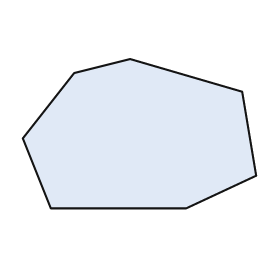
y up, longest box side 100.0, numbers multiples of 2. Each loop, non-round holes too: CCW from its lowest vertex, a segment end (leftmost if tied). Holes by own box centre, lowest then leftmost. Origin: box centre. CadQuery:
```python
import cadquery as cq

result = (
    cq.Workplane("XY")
    .moveTo(-38.0, -32.0)
    .lineTo(20.0, -32.0)
    .lineTo(50.0, -18.0)
    .lineTo(44.0, 18.0)
    .lineTo(-4.0, 32.0)
    .lineTo(-28.0, 26.0)
    .lineTo(-50.0, -2.0)
    .close()
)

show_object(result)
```